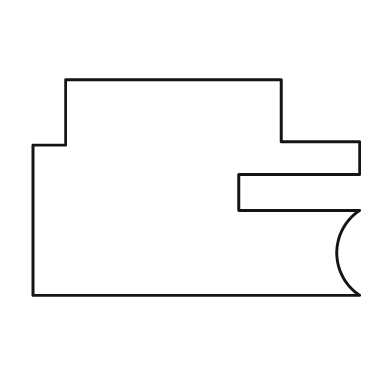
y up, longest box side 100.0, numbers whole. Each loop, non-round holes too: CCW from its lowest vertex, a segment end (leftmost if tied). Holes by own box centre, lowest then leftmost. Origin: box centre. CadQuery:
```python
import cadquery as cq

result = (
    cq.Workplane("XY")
    .moveTo(-50.0, -33.0)
    .lineTo(50.0, -33.0)
    .threePointArc((43.0, -20.0), (50.0, -7.0))
    .lineTo(13.0, -7.0)
    .lineTo(13.0, 4.0)
    .lineTo(50.0, 4.0)
    .lineTo(50.0, 14.0)
    .lineTo(26.0, 14.0)
    .lineTo(26.0, 33.0)
    .lineTo(-40.0, 33.0)
    .lineTo(-40.0, 13.0)
    .lineTo(-50.0, 13.0)
    .close()
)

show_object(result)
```